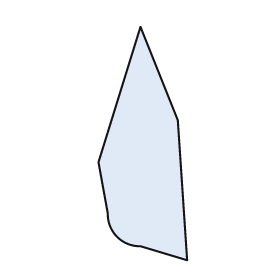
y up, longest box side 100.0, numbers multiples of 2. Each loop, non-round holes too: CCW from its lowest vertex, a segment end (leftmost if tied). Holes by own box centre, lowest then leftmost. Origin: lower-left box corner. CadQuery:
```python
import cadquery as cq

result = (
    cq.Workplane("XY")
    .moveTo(38.0, 0.0)
    .lineTo(34.0, 60.0)
    .lineTo(18.0, 100.0)
    .lineTo(0.0, 42.0)
    .lineTo(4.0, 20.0)
    .threePointArc((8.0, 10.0), (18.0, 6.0))
    .close()
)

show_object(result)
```